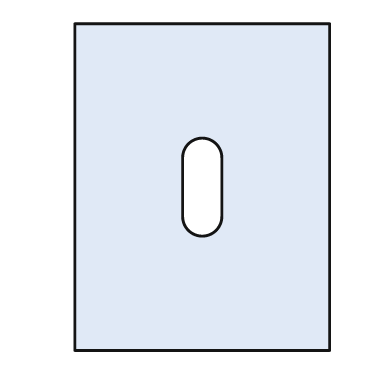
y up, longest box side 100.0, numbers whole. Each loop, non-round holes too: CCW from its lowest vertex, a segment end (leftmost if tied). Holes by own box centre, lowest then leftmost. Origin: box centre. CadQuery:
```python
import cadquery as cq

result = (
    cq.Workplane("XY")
    .moveTo(-39.0, -50.0)
    .lineTo(39.0, -50.0)
    .lineTo(39.0, 50.0)
    .lineTo(-39.0, 50.0)
    .close()
    .moveTo(-6.0, -9.0)
    .threePointArc((0.0, -15.0), (6.0, -9.0))
    .lineTo(6.0, 9.0)
    .threePointArc((0.0, 15.0), (-6.0, 9.0))
    .close()
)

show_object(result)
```